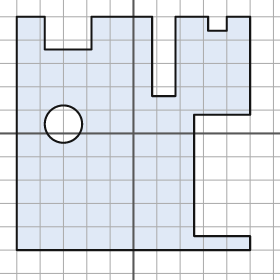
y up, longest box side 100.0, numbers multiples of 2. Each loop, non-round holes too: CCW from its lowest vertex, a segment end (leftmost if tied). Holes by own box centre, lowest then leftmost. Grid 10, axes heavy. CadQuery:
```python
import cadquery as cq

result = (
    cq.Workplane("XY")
    .moveTo(-50.0, -50.0)
    .lineTo(50.0, -50.0)
    .lineTo(50.0, -44.0)
    .lineTo(26.0, -44.0)
    .lineTo(26.0, 8.0)
    .lineTo(50.0, 8.0)
    .lineTo(50.0, 50.0)
    .lineTo(40.0, 50.0)
    .lineTo(40.0, 44.0)
    .lineTo(32.0, 44.0)
    .lineTo(32.0, 50.0)
    .lineTo(18.0, 50.0)
    .lineTo(18.0, 16.0)
    .lineTo(8.0, 16.0)
    .lineTo(8.0, 50.0)
    .lineTo(-18.0, 50.0)
    .lineTo(-18.0, 36.0)
    .lineTo(-38.0, 36.0)
    .lineTo(-38.0, 50.0)
    .lineTo(-50.0, 50.0)
    .close()
    .moveTo(-30.0, 4.0)
    .circle(8.0)
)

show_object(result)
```